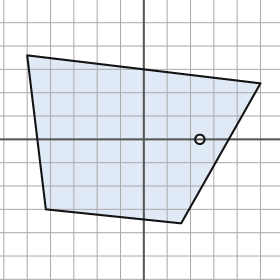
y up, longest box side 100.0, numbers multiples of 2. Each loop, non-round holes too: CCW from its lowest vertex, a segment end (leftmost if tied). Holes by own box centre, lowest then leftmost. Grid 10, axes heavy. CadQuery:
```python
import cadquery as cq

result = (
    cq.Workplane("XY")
    .moveTo(16.0, -36.0)
    .lineTo(50.0, 24.0)
    .lineTo(-50.0, 36.0)
    .lineTo(-42.0, -30.0)
    .close()
    .moveTo(24.0, 0.0)
    .circle(2.0)
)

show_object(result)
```